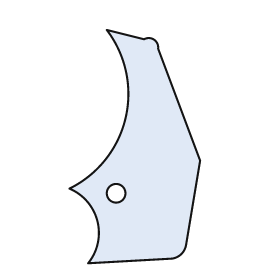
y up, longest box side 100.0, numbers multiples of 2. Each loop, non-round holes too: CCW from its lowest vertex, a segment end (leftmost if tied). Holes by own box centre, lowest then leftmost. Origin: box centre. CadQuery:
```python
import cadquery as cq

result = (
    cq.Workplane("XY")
    .moveTo(-20.0, -50.0)
    .lineTo(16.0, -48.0)
    .threePointArc((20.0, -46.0), (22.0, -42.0))
    .lineTo(28.0, -6.0)
    .lineTo(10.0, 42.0)
    .threePointArc((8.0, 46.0), (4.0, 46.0))
    .lineTo(-12.0, 50.0)
    .threePointArc((-4.0, 12.0), (-28.0, -18.0))
    .threePointArc((-16.0, -32.0), (-20.0, -50.0))
    .close()
    .moveTo(-8.0, -20.0)
    .circle(4.0)
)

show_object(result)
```